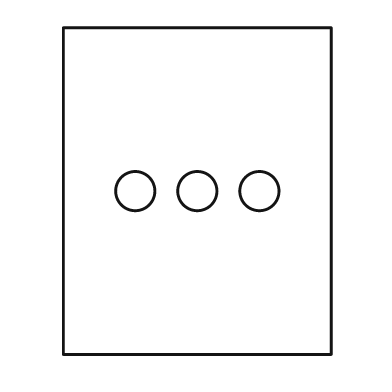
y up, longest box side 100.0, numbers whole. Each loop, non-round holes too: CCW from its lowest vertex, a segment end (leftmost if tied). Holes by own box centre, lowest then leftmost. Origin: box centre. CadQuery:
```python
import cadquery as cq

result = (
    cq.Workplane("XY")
    .moveTo(-41.0, -50.0)
    .lineTo(41.0, -50.0)
    .lineTo(41.0, 50.0)
    .lineTo(-41.0, 50.0)
    .close()
    .moveTo(-19.0, 0.0)
    .circle(6.0)
    .moveTo(0.0, 0.0)
    .circle(6.0)
    .moveTo(19.0, 0.0)
    .circle(6.0)
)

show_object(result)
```